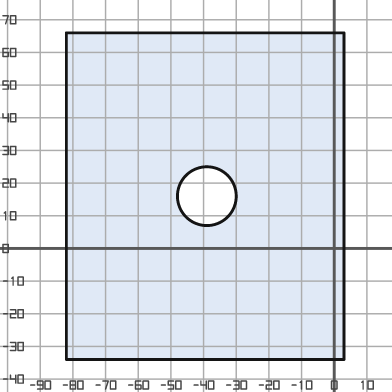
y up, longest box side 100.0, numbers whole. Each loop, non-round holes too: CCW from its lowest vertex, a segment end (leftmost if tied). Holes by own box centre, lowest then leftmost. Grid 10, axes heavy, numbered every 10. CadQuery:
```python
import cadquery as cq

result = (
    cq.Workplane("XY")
    .moveTo(-82.0, -34.0)
    .lineTo(3.0, -34.0)
    .lineTo(3.0, 66.0)
    .lineTo(-82.0, 66.0)
    .close()
    .moveTo(-39.0, 16.0)
    .circle(9.0)
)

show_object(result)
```